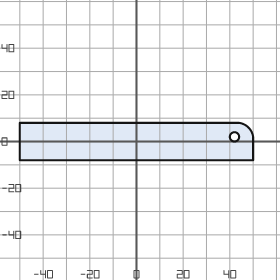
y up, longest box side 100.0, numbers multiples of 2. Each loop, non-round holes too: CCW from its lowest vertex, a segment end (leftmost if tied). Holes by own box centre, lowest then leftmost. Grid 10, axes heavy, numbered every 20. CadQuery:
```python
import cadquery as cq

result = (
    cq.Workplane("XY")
    .moveTo(-50.0, -8.0)
    .lineTo(50.0, -8.0)
    .lineTo(50.0, 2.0)
    .threePointArc((48.0, 6.0), (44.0, 8.0))
    .lineTo(-50.0, 8.0)
    .close()
    .moveTo(42.0, 2.0)
    .circle(2.0)
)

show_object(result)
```